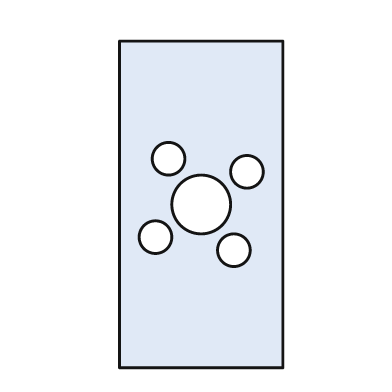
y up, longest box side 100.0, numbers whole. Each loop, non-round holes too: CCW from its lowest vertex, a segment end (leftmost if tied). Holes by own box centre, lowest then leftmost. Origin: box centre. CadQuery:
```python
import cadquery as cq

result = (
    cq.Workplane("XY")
    .moveTo(-25.0, -50.0)
    .lineTo(25.0, -50.0)
    .lineTo(25.0, 50.0)
    .lineTo(-25.0, 50.0)
    .close()
    .moveTo(10.0, -14.0)
    .circle(5.0)
    .moveTo(-14.0, -10.0)
    .circle(5.0)
    .moveTo(0.0, 0.0)
    .circle(9.0)
    .moveTo(14.0, 10.0)
    .circle(5.0)
    .moveTo(-10.0, 14.0)
    .circle(5.0)
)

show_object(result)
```